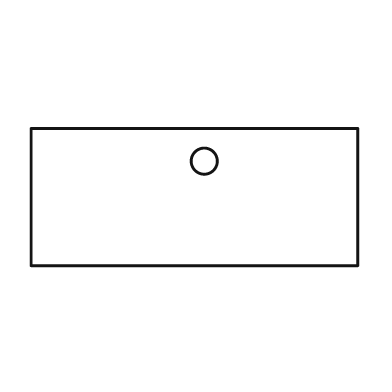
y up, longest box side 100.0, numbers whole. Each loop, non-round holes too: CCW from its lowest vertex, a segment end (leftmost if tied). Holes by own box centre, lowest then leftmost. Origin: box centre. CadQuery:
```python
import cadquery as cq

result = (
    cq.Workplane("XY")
    .moveTo(-50.0, -21.0)
    .lineTo(50.0, -21.0)
    .lineTo(50.0, 21.0)
    .lineTo(-50.0, 21.0)
    .close()
    .moveTo(3.0, 11.0)
    .circle(4.0)
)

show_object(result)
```